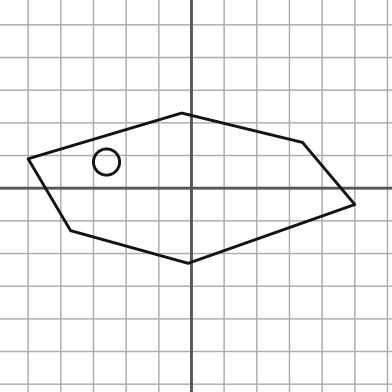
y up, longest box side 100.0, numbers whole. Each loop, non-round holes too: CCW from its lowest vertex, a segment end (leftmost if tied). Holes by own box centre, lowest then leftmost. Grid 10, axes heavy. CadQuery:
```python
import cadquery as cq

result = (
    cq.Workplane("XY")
    .moveTo(-1.0, -23.0)
    .lineTo(50.0, -5.0)
    .lineTo(34.0, 14.0)
    .lineTo(-3.0, 23.0)
    .lineTo(-50.0, 9.0)
    .lineTo(-37.0, -13.0)
    .close()
    .moveTo(-26.0, 8.0)
    .circle(4.0)
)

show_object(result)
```